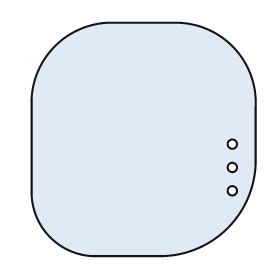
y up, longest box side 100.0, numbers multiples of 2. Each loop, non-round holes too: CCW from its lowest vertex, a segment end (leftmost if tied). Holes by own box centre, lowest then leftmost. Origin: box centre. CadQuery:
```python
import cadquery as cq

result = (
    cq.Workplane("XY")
    .moveTo(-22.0, -50.0)
    .lineTo(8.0, -50.0)
    .threePointArc((36.0, -38.0), (48.0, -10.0))
    .lineTo(48.0, 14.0)
    .threePointArc((38.0, 40.0), (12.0, 50.0))
    .lineTo(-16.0, 50.0)
    .threePointArc((-38.0, 40.0), (-48.0, 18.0))
    .lineTo(-48.0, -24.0)
    .threePointArc((-40.0, -42.0), (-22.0, -50.0))
    .close()
    .moveTo(38.0, -22.0)
    .circle(2.0)
    .moveTo(38.0, -12.0)
    .circle(2.0)
    .moveTo(38.0, -2.0)
    .circle(2.0)
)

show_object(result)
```